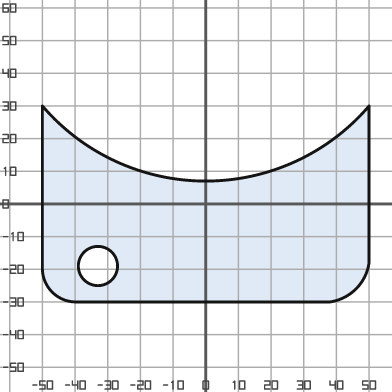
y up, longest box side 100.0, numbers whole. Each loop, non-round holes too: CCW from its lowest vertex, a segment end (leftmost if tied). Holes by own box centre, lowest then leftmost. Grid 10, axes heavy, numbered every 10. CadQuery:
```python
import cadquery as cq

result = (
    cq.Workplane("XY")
    .moveTo(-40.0, -30.0)
    .lineTo(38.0, -30.0)
    .threePointArc((46.0, -26.0), (50.0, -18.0))
    .lineTo(50.0, 30.0)
    .threePointArc((0.0, 7.0), (-50.0, 30.0))
    .lineTo(-50.0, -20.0)
    .threePointArc((-47.0, -27.0), (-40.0, -30.0))
    .close()
    .moveTo(-33.0, -19.0)
    .circle(6.0)
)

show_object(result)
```